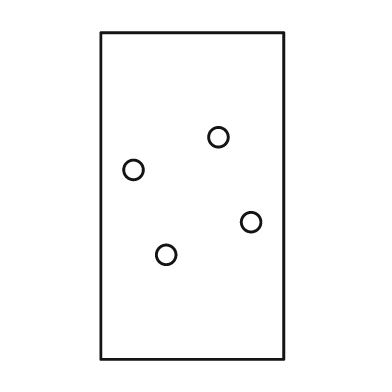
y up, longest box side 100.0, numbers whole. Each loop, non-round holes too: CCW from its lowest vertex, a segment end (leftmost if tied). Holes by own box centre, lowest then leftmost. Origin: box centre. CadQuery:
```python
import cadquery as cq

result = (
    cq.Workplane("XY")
    .moveTo(-28.0, -50.0)
    .lineTo(28.0, -50.0)
    .lineTo(28.0, 50.0)
    .lineTo(-28.0, 50.0)
    .close()
    .moveTo(-8.0, -18.0)
    .circle(3.0)
    .moveTo(18.0, -8.0)
    .circle(3.0)
    .moveTo(-18.0, 8.0)
    .circle(3.0)
    .moveTo(8.0, 18.0)
    .circle(3.0)
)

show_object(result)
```